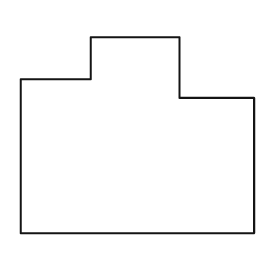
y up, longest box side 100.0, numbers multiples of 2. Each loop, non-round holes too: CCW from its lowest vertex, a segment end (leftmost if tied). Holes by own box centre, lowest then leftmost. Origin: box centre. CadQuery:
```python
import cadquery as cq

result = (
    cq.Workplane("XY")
    .moveTo(-50.0, -42.0)
    .lineTo(50.0, -42.0)
    .lineTo(50.0, 16.0)
    .lineTo(18.0, 16.0)
    .lineTo(18.0, 42.0)
    .lineTo(-20.0, 42.0)
    .lineTo(-20.0, 24.0)
    .lineTo(-50.0, 24.0)
    .close()
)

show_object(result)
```